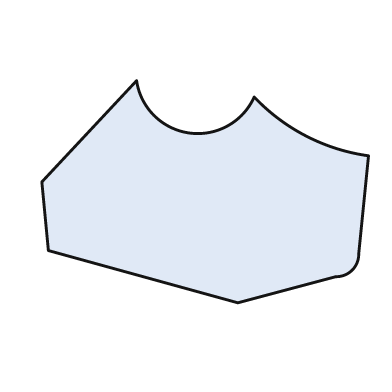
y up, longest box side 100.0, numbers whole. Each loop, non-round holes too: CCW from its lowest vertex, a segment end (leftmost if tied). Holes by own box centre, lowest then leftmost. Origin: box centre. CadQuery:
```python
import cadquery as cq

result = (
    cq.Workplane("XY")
    .moveTo(10.0, -34.0)
    .lineTo(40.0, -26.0)
    .threePointArc((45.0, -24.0), (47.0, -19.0))
    .lineTo(50.0, 11.0)
    .threePointArc((31.0, 17.0), (15.0, 29.0))
    .threePointArc((-5.0, 18.0), (-21.0, 34.0))
    .lineTo(-50.0, 3.0)
    .lineTo(-48.0, -18.0)
    .close()
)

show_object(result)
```